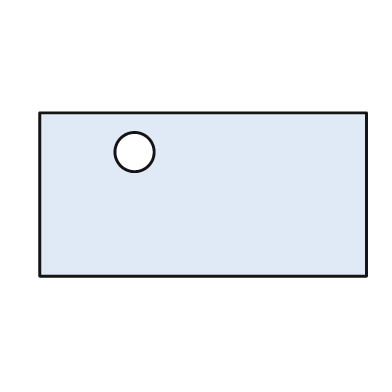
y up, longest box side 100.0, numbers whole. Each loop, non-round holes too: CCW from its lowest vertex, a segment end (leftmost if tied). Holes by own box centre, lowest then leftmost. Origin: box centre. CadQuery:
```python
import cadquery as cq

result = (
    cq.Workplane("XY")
    .moveTo(-50.0, -25.0)
    .lineTo(50.0, -25.0)
    .lineTo(50.0, 25.0)
    .lineTo(-50.0, 25.0)
    .close()
    .moveTo(-21.0, 13.0)
    .circle(6.0)
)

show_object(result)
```